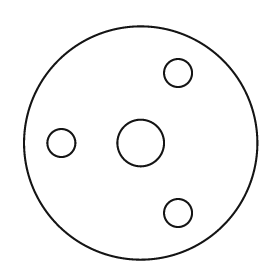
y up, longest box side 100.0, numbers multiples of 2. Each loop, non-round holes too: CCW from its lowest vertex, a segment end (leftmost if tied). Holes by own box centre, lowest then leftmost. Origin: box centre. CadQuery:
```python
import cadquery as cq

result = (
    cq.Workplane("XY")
    .moveTo(0.0, 0.0)
    .circle(50.0)
    .moveTo(16.0, -30.0)
    .circle(6.0)
    .moveTo(-34.0, 0.0)
    .circle(6.0)
    .moveTo(0.0, 0.0)
    .circle(10.0)
    .moveTo(16.0, 30.0)
    .circle(6.0)
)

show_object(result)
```